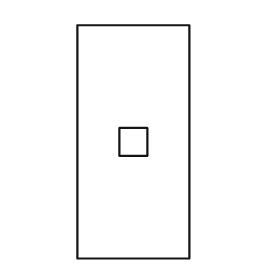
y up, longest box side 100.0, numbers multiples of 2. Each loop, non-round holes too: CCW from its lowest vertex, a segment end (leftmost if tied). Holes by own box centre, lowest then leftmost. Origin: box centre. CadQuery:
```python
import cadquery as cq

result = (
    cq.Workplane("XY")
    .moveTo(-24.0, -50.0)
    .lineTo(24.0, -50.0)
    .lineTo(24.0, 50.0)
    .lineTo(-24.0, 50.0)
    .close()
    .moveTo(-6.0, -6.0)
    .lineTo(6.0, -6.0)
    .lineTo(6.0, 6.0)
    .lineTo(-6.0, 6.0)
    .close()
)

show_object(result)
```